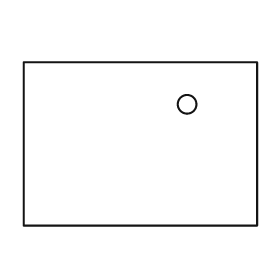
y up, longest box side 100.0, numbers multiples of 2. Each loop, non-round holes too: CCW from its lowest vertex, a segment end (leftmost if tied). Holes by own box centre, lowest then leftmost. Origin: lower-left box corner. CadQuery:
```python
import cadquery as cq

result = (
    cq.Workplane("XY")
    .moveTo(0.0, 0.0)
    .lineTo(100.0, 0.0)
    .lineTo(100.0, 70.0)
    .lineTo(0.0, 70.0)
    .close()
    .moveTo(70.0, 52.0)
    .circle(4.0)
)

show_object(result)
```